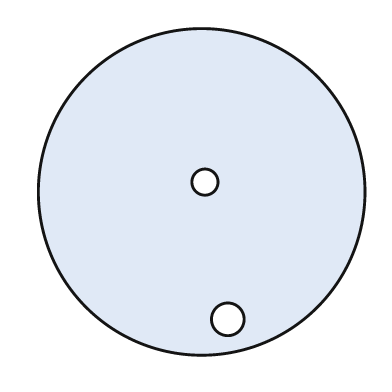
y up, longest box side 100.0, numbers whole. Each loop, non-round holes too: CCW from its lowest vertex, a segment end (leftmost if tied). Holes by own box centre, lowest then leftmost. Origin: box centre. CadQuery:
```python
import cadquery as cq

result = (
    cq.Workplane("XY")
    .moveTo(0.0, 0.0)
    .circle(50.0)
    .moveTo(8.0, -39.0)
    .circle(5.0)
    .moveTo(1.0, 3.0)
    .circle(4.0)
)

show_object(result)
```